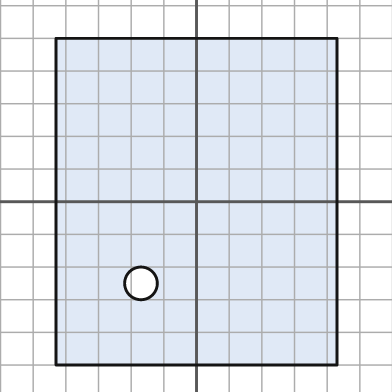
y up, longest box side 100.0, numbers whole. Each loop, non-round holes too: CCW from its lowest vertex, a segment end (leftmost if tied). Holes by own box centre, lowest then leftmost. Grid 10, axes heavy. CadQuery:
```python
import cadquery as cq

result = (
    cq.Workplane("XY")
    .moveTo(-43.0, -50.0)
    .lineTo(43.0, -50.0)
    .lineTo(43.0, 50.0)
    .lineTo(-43.0, 50.0)
    .close()
    .moveTo(-17.0, -25.0)
    .circle(5.0)
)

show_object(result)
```